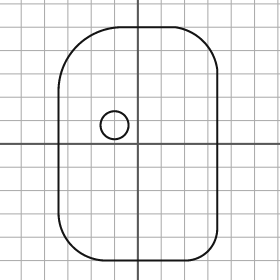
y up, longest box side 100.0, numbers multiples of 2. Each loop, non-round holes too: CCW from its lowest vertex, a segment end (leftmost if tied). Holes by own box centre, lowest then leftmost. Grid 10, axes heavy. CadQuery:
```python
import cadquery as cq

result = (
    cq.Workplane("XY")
    .moveTo(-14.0, -50.0)
    .lineTo(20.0, -50.0)
    .threePointArc((30.0, -46.0), (34.0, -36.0))
    .lineTo(34.0, 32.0)
    .threePointArc((28.0, 44.0), (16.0, 50.0))
    .lineTo(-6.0, 50.0)
    .threePointArc((-26.0, 42.0), (-34.0, 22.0))
    .lineTo(-34.0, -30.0)
    .threePointArc((-28.0, -44.0), (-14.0, -50.0))
    .close()
    .moveTo(-10.0, 8.0)
    .circle(6.0)
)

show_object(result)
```